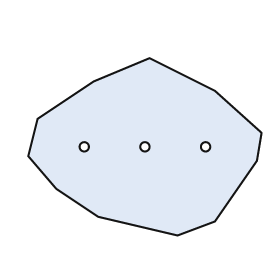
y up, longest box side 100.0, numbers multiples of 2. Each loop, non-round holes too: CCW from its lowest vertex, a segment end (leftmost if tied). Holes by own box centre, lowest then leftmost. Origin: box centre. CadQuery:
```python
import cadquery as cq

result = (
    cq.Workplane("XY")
    .moveTo(14.0, -38.0)
    .lineTo(30.0, -32.0)
    .lineTo(48.0, -6.0)
    .lineTo(50.0, 6.0)
    .lineTo(30.0, 24.0)
    .lineTo(2.0, 38.0)
    .lineTo(-22.0, 28.0)
    .lineTo(-46.0, 12.0)
    .lineTo(-50.0, -4.0)
    .lineTo(-38.0, -18.0)
    .lineTo(-20.0, -30.0)
    .close()
    .moveTo(-26.0, 0.0)
    .circle(2.0)
    .moveTo(0.0, 0.0)
    .circle(2.0)
    .moveTo(26.0, 0.0)
    .circle(2.0)
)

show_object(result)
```